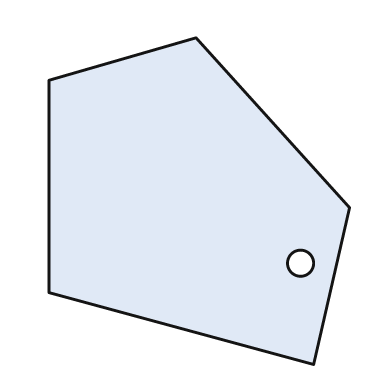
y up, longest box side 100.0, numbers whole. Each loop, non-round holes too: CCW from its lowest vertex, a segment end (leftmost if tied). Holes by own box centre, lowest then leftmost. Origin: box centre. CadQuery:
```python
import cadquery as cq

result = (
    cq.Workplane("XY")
    .moveTo(35.0, -50.0)
    .lineTo(46.0, -2.0)
    .lineTo(-1.0, 50.0)
    .lineTo(-46.0, 37.0)
    .lineTo(-46.0, -28.0)
    .close()
    .moveTo(31.0, -19.0)
    .circle(4.0)
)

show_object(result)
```